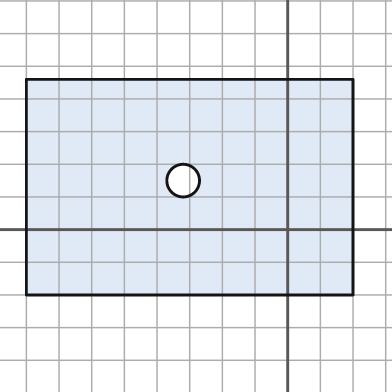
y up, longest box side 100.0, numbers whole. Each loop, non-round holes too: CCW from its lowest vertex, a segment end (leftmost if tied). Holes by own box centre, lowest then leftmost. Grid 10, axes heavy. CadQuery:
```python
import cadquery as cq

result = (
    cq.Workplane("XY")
    .moveTo(-80.0, -20.0)
    .lineTo(20.0, -20.0)
    .lineTo(20.0, 46.0)
    .lineTo(-80.0, 46.0)
    .close()
    .moveTo(-32.0, 15.0)
    .circle(5.0)
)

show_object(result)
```